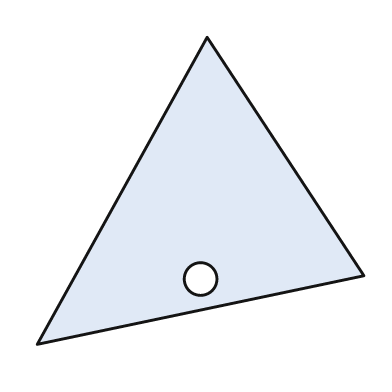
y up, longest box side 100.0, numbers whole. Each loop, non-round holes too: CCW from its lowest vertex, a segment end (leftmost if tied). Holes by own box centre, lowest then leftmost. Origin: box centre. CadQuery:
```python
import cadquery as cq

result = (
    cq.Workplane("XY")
    .moveTo(-50.0, -47.0)
    .lineTo(50.0, -26.0)
    .lineTo(2.0, 47.0)
    .close()
    .moveTo(0.0, -27.0)
    .circle(5.0)
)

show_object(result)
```